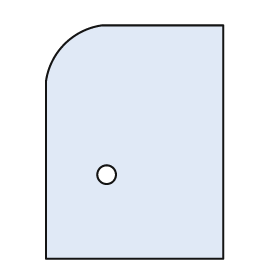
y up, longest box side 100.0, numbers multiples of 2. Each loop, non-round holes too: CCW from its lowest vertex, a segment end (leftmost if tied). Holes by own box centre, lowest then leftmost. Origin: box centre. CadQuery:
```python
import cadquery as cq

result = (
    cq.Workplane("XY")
    .moveTo(-38.0, -50.0)
    .lineTo(38.0, -50.0)
    .lineTo(38.0, 50.0)
    .lineTo(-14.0, 50.0)
    .threePointArc((-30.0, 42.0), (-38.0, 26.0))
    .close()
    .moveTo(-12.0, -14.0)
    .circle(4.0)
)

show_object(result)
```